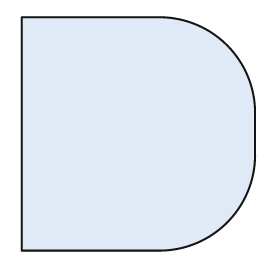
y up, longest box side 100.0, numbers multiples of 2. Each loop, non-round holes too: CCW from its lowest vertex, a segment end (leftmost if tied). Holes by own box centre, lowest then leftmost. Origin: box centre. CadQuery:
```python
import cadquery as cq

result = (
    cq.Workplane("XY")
    .moveTo(-50.0, -50.0)
    .lineTo(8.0, -50.0)
    .threePointArc((38.0, -38.0), (50.0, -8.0))
    .lineTo(50.0, 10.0)
    .threePointArc((38.0, 38.0), (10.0, 50.0))
    .lineTo(-50.0, 50.0)
    .close()
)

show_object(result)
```